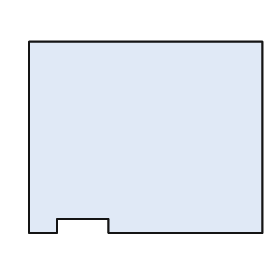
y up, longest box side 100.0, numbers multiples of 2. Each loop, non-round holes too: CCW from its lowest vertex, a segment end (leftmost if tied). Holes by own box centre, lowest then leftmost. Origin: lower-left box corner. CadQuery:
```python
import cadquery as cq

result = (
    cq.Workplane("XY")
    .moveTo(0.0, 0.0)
    .lineTo(12.0, 0.0)
    .lineTo(12.0, 6.0)
    .lineTo(34.0, 6.0)
    .lineTo(34.0, 0.0)
    .lineTo(100.0, 0.0)
    .lineTo(100.0, 82.0)
    .lineTo(0.0, 82.0)
    .close()
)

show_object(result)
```